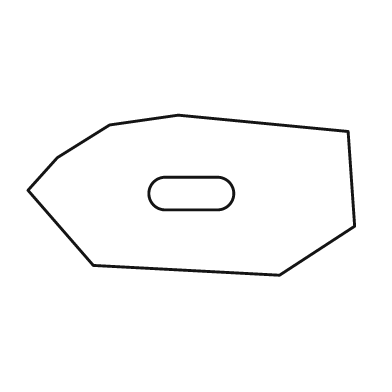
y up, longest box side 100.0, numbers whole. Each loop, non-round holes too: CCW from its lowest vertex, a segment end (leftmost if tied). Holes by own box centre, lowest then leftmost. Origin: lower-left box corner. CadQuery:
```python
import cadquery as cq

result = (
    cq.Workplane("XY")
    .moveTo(77.0, 0.0)
    .lineTo(100.0, 15.0)
    .lineTo(98.0, 44.0)
    .lineTo(46.0, 49.0)
    .lineTo(25.0, 46.0)
    .lineTo(9.0, 36.0)
    .lineTo(0.0, 26.0)
    .lineTo(20.0, 3.0)
    .close()
    .moveTo(42.0, 20.0)
    .lineTo(58.0, 20.0)
    .threePointArc((63.0, 25.0), (58.0, 30.0))
    .lineTo(42.0, 30.0)
    .threePointArc((37.0, 25.0), (42.0, 20.0))
    .close()
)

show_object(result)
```